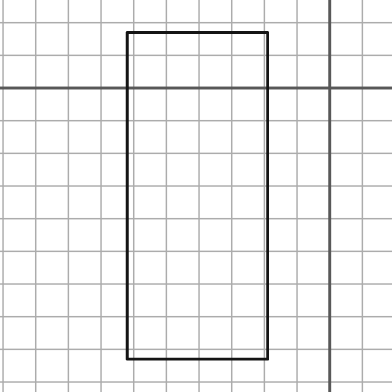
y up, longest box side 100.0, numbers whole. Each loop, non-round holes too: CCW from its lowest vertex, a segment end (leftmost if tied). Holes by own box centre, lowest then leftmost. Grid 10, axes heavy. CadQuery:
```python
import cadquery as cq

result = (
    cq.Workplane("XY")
    .moveTo(-62.0, -83.0)
    .lineTo(-19.0, -83.0)
    .lineTo(-19.0, 17.0)
    .lineTo(-62.0, 17.0)
    .close()
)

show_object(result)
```